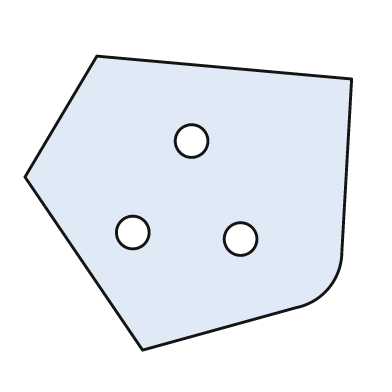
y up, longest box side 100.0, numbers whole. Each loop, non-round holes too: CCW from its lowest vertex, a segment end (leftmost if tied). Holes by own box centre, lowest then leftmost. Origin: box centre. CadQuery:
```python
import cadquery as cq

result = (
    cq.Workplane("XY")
    .moveTo(-14.0, -45.0)
    .lineTo(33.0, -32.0)
    .threePointArc((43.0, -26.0), (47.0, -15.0))
    .lineTo(50.0, 38.0)
    .lineTo(-28.0, 45.0)
    .lineTo(-50.0, 8.0)
    .close()
    .moveTo(16.0, -11.0)
    .circle(5.0)
    .moveTo(-17.0, -9.0)
    .circle(5.0)
    .moveTo(1.0, 19.0)
    .circle(5.0)
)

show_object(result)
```